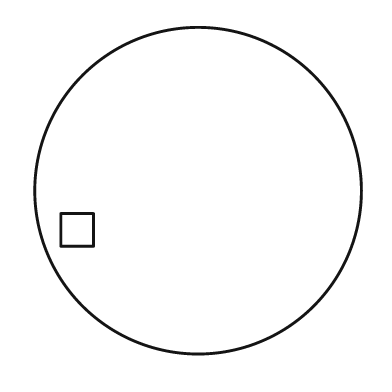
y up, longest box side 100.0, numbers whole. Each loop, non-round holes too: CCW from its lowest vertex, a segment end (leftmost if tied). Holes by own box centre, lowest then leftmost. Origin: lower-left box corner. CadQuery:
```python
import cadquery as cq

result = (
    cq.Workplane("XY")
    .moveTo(50.0, 50.0)
    .circle(50.0)
    .moveTo(8.0, 33.0)
    .lineTo(18.0, 33.0)
    .lineTo(18.0, 43.0)
    .lineTo(8.0, 43.0)
    .close()
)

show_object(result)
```